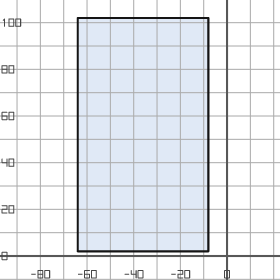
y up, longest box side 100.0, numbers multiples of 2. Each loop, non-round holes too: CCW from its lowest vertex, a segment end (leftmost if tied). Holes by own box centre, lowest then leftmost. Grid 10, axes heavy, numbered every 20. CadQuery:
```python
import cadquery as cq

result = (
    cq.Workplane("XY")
    .moveTo(-64.0, 2.0)
    .lineTo(-8.0, 2.0)
    .lineTo(-8.0, 102.0)
    .lineTo(-64.0, 102.0)
    .close()
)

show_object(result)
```